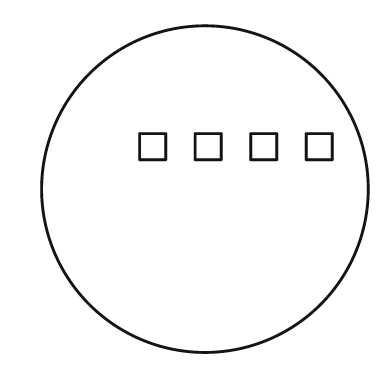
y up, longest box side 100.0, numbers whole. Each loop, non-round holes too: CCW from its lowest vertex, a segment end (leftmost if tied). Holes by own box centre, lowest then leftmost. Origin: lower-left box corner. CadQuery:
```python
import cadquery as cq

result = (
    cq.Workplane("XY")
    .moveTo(50.0, 50.0)
    .circle(50.0)
    .moveTo(30.0, 59.0)
    .lineTo(38.0, 59.0)
    .lineTo(38.0, 67.0)
    .lineTo(30.0, 67.0)
    .close()
    .moveTo(47.0, 59.0)
    .lineTo(55.0, 59.0)
    .lineTo(55.0, 67.0)
    .lineTo(47.0, 67.0)
    .close()
    .moveTo(64.0, 59.0)
    .lineTo(72.0, 59.0)
    .lineTo(72.0, 67.0)
    .lineTo(64.0, 67.0)
    .close()
    .moveTo(81.0, 59.0)
    .lineTo(89.0, 59.0)
    .lineTo(89.0, 67.0)
    .lineTo(81.0, 67.0)
    .close()
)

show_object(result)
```